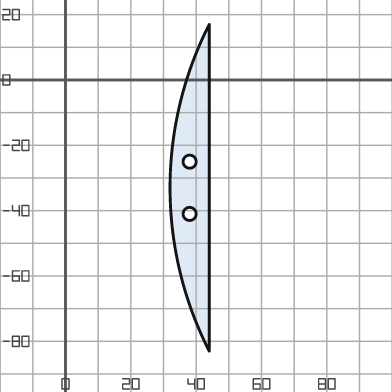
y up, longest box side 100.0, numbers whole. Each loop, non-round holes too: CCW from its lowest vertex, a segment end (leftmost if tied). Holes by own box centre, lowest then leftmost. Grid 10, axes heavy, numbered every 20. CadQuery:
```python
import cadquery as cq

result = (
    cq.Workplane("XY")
    .moveTo(44.0, -83.0)
    .lineTo(44.0, 17.0)
    .threePointArc((32.0, -33.0), (44.0, -83.0))
    .close()
    .moveTo(38.0, -41.0)
    .circle(2.0)
    .moveTo(38.0, -25.0)
    .circle(2.0)
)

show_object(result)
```